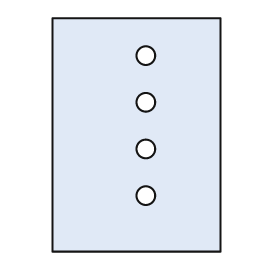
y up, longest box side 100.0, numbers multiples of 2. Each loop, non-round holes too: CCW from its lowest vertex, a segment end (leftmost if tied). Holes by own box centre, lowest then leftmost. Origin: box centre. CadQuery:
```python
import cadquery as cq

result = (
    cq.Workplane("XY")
    .moveTo(-36.0, -50.0)
    .lineTo(36.0, -50.0)
    .lineTo(36.0, 50.0)
    .lineTo(-36.0, 50.0)
    .close()
    .moveTo(4.0, -26.0)
    .circle(4.0)
    .moveTo(4.0, -6.0)
    .circle(4.0)
    .moveTo(4.0, 14.0)
    .circle(4.0)
    .moveTo(4.0, 34.0)
    .circle(4.0)
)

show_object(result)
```